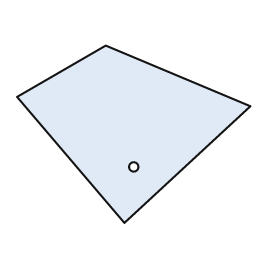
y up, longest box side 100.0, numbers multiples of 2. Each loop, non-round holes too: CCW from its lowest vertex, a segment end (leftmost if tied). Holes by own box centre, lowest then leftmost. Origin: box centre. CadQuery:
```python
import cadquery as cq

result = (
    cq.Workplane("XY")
    .moveTo(-4.0, -38.0)
    .lineTo(50.0, 12.0)
    .lineTo(-12.0, 38.0)
    .lineTo(-50.0, 16.0)
    .close()
    .moveTo(0.0, -14.0)
    .circle(2.0)
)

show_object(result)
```